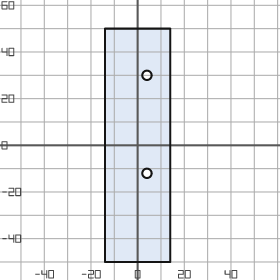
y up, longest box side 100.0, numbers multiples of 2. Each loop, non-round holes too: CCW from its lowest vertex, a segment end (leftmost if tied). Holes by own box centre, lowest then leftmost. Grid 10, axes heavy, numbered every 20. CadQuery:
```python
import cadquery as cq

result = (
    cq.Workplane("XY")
    .moveTo(-14.0, -50.0)
    .lineTo(14.0, -50.0)
    .lineTo(14.0, 50.0)
    .lineTo(-14.0, 50.0)
    .close()
    .moveTo(4.0, -12.0)
    .circle(2.0)
    .moveTo(4.0, 30.0)
    .circle(2.0)
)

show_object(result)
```